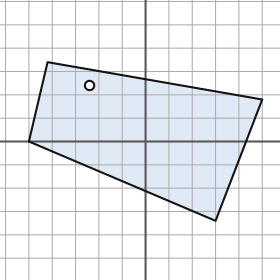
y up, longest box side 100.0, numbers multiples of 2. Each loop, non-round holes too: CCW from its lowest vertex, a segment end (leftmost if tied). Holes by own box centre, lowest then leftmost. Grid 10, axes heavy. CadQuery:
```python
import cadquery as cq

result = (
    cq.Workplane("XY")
    .moveTo(30.0, -34.0)
    .lineTo(50.0, 18.0)
    .lineTo(-42.0, 34.0)
    .lineTo(-50.0, 0.0)
    .close()
    .moveTo(-24.0, 24.0)
    .circle(2.0)
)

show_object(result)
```